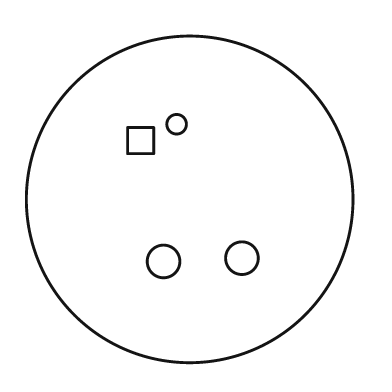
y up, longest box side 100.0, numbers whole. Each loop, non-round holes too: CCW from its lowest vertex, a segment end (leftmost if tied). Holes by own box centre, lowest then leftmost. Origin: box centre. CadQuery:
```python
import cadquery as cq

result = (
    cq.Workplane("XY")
    .moveTo(0.0, 0.0)
    .circle(50.0)
    .moveTo(-8.0, -19.0)
    .circle(5.0)
    .moveTo(16.0, -18.0)
    .circle(5.0)
    .moveTo(-19.0, 14.0)
    .lineTo(-11.0, 14.0)
    .lineTo(-11.0, 22.0)
    .lineTo(-19.0, 22.0)
    .close()
    .moveTo(-4.0, 23.0)
    .circle(3.0)
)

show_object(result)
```